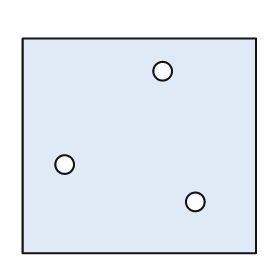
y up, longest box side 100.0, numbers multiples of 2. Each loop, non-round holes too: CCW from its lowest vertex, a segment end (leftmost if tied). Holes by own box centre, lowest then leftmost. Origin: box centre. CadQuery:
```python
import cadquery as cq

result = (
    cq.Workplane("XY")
    .moveTo(-50.0, -46.0)
    .lineTo(50.0, -46.0)
    .lineTo(50.0, 46.0)
    .lineTo(-50.0, 46.0)
    .close()
    .moveTo(24.0, -24.0)
    .circle(4.0)
    .moveTo(-32.0, -8.0)
    .circle(4.0)
    .moveTo(10.0, 32.0)
    .circle(4.0)
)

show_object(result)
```